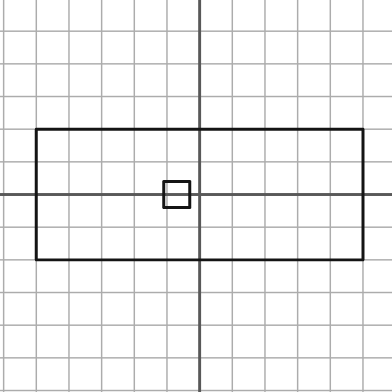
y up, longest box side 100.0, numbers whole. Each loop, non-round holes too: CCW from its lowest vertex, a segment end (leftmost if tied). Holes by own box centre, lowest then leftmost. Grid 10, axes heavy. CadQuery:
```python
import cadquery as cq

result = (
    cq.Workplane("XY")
    .moveTo(-50.0, -20.0)
    .lineTo(50.0, -20.0)
    .lineTo(50.0, 20.0)
    .lineTo(-50.0, 20.0)
    .close()
    .moveTo(-11.0, -4.0)
    .lineTo(-3.0, -4.0)
    .lineTo(-3.0, 4.0)
    .lineTo(-11.0, 4.0)
    .close()
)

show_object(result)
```